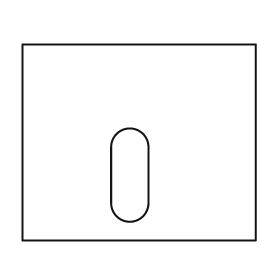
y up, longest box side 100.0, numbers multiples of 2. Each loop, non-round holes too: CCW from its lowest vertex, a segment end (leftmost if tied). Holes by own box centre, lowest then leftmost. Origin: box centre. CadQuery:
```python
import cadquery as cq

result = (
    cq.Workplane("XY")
    .moveTo(-50.0, -42.0)
    .lineTo(50.0, -42.0)
    .lineTo(50.0, 42.0)
    .lineTo(-50.0, 42.0)
    .close()
    .moveTo(-12.0, -26.0)
    .threePointArc((-4.0, -34.0), (4.0, -26.0))
    .lineTo(4.0, -2.0)
    .threePointArc((-4.0, 6.0), (-12.0, -2.0))
    .close()
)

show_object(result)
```